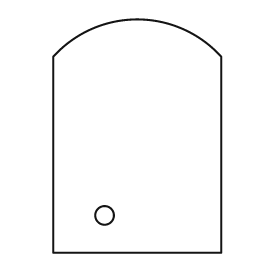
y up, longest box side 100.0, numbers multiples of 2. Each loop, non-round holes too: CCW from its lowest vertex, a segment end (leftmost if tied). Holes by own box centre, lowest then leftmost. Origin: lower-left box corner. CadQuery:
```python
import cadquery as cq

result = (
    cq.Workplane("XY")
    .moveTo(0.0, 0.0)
    .lineTo(72.0, 0.0)
    .lineTo(72.0, 84.0)
    .threePointArc((36.0, 100.0), (0.0, 84.0))
    .close()
    .moveTo(22.0, 16.0)
    .circle(4.0)
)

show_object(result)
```